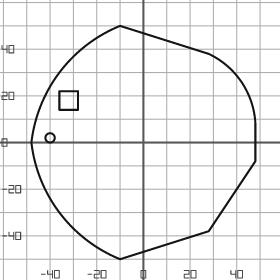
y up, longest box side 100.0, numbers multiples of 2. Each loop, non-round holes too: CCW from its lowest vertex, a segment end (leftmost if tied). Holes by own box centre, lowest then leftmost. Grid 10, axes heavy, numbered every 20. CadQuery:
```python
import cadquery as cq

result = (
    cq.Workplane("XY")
    .moveTo(-10.0, -50.0)
    .lineTo(28.0, -38.0)
    .lineTo(48.0, -8.0)
    .lineTo(48.0, 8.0)
    .threePointArc((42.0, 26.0), (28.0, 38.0))
    .lineTo(-10.0, 50.0)
    .threePointArc((-36.0, 30.0), (-48.0, 0.0))
    .threePointArc((-36.0, -30.0), (-10.0, -50.0))
    .close()
    .moveTo(-40.0, 2.0)
    .circle(2.0)
    .moveTo(-36.0, 14.0)
    .lineTo(-28.0, 14.0)
    .lineTo(-28.0, 22.0)
    .lineTo(-36.0, 22.0)
    .close()
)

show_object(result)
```